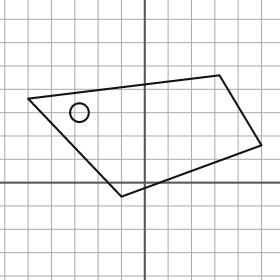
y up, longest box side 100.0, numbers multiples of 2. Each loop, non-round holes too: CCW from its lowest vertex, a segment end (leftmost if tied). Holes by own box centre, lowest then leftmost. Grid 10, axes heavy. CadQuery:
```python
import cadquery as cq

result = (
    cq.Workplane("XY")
    .moveTo(-10.0, -6.0)
    .lineTo(50.0, 16.0)
    .lineTo(32.0, 46.0)
    .lineTo(-50.0, 36.0)
    .close()
    .moveTo(-28.0, 30.0)
    .circle(4.0)
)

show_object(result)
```